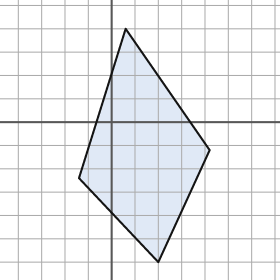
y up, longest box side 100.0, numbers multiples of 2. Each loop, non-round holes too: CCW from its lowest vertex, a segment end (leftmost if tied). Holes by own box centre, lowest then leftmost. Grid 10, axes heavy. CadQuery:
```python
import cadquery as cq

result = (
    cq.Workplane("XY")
    .moveTo(20.0, -60.0)
    .lineTo(42.0, -12.0)
    .lineTo(6.0, 40.0)
    .lineTo(-14.0, -24.0)
    .close()
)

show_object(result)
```